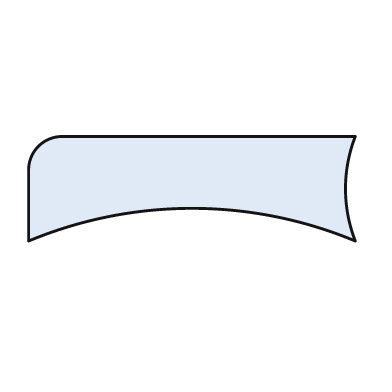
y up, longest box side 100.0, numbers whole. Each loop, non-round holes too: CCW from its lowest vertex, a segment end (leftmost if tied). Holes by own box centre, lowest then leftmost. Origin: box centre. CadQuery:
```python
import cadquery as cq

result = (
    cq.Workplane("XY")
    .moveTo(-50.0, -16.0)
    .threePointArc((0.0, -6.0), (50.0, -16.0))
    .threePointArc((47.0, 0.0), (50.0, 16.0))
    .lineTo(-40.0, 16.0)
    .threePointArc((-47.0, 13.0), (-50.0, 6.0))
    .close()
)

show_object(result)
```